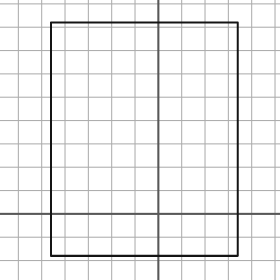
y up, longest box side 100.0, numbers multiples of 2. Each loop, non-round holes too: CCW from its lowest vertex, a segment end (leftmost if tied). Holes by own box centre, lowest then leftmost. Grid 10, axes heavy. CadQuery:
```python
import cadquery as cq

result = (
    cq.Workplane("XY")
    .moveTo(-46.0, -18.0)
    .lineTo(34.0, -18.0)
    .lineTo(34.0, 82.0)
    .lineTo(-46.0, 82.0)
    .close()
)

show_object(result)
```